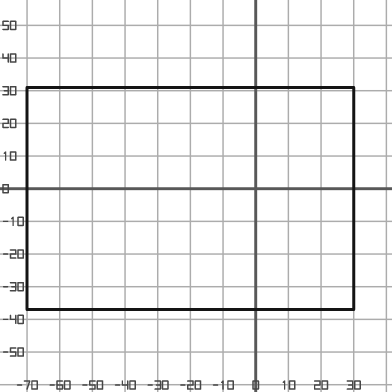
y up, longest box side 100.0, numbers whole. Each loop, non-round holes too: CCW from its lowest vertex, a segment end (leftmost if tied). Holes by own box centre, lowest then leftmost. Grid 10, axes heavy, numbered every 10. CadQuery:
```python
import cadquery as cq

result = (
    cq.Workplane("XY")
    .moveTo(-70.0, -37.0)
    .lineTo(30.0, -37.0)
    .lineTo(30.0, 31.0)
    .lineTo(-70.0, 31.0)
    .close()
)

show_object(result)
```